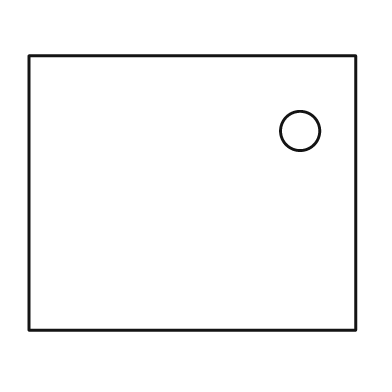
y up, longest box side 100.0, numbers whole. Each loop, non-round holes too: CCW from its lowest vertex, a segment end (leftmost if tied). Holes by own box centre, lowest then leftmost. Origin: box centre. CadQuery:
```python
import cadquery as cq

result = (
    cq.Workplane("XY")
    .moveTo(-50.0, -42.0)
    .lineTo(50.0, -42.0)
    .lineTo(50.0, 42.0)
    .lineTo(-50.0, 42.0)
    .close()
    .moveTo(33.0, 19.0)
    .circle(6.0)
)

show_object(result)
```